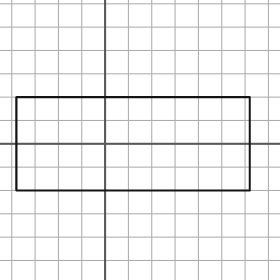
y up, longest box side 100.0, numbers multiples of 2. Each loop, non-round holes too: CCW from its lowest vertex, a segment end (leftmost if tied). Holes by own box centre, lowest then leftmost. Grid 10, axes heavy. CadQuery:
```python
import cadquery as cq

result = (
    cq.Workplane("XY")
    .moveTo(-38.0, -20.0)
    .lineTo(62.0, -20.0)
    .lineTo(62.0, 20.0)
    .lineTo(-38.0, 20.0)
    .close()
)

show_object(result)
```